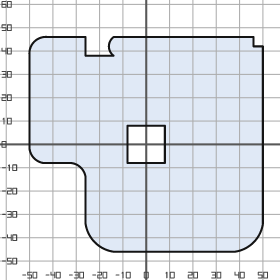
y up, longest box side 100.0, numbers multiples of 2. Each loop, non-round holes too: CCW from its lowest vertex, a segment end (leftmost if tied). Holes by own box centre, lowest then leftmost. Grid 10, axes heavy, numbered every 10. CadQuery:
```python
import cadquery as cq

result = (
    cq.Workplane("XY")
    .moveTo(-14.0, -46.0)
    .lineTo(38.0, -46.0)
    .threePointArc((46.0, -42.0), (50.0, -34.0))
    .lineTo(50.0, 42.0)
    .lineTo(46.0, 42.0)
    .lineTo(46.0, 46.0)
    .lineTo(-14.0, 46.0)
    .threePointArc((-16.0, 42.0), (-14.0, 38.0))
    .lineTo(-26.0, 38.0)
    .lineTo(-26.0, 46.0)
    .lineTo(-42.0, 46.0)
    .threePointArc((-48.0, 44.0), (-50.0, 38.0))
    .lineTo(-50.0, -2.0)
    .threePointArc((-48.0, -6.0), (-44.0, -8.0))
    .lineTo(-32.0, -8.0)
    .threePointArc((-28.0, -10.0), (-26.0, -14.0))
    .lineTo(-26.0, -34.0)
    .threePointArc((-22.0, -42.0), (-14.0, -46.0))
    .close()
    .moveTo(-8.0, -8.0)
    .lineTo(8.0, -8.0)
    .lineTo(8.0, 8.0)
    .lineTo(-8.0, 8.0)
    .close()
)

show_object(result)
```